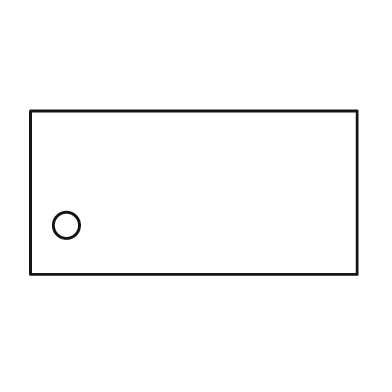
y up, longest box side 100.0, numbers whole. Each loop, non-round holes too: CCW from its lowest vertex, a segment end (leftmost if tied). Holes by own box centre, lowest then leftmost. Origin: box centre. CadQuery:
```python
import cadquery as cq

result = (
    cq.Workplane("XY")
    .moveTo(-50.0, -25.0)
    .lineTo(50.0, -25.0)
    .lineTo(50.0, 25.0)
    .lineTo(-50.0, 25.0)
    .close()
    .moveTo(-39.0, -10.0)
    .circle(4.0)
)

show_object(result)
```